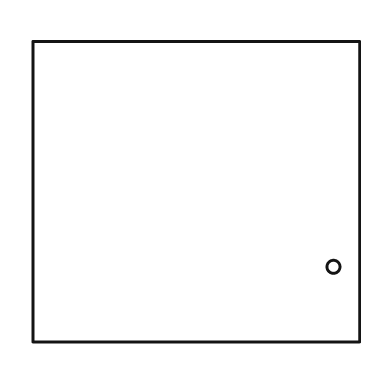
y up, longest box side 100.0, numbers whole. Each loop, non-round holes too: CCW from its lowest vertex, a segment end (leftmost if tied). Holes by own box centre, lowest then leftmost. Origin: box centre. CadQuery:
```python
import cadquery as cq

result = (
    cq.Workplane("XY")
    .moveTo(-50.0, -46.0)
    .lineTo(50.0, -46.0)
    .lineTo(50.0, 46.0)
    .lineTo(-50.0, 46.0)
    .close()
    .moveTo(42.0, -23.0)
    .circle(2.0)
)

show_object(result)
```